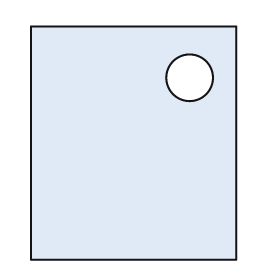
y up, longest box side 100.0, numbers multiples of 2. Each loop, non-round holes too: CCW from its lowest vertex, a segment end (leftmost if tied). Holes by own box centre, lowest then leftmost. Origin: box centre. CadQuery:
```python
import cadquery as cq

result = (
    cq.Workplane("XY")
    .moveTo(-44.0, -50.0)
    .lineTo(44.0, -50.0)
    .lineTo(44.0, 50.0)
    .lineTo(-44.0, 50.0)
    .close()
    .moveTo(24.0, 28.0)
    .circle(10.0)
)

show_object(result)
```